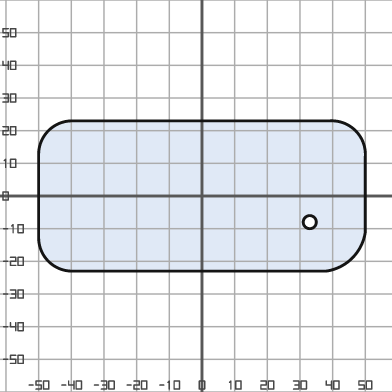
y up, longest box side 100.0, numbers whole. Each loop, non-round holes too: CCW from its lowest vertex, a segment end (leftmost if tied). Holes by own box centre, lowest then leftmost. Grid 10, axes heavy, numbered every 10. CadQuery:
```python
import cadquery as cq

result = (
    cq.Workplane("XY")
    .moveTo(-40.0, -23.0)
    .lineTo(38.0, -23.0)
    .threePointArc((46.0, -19.0), (50.0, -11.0))
    .lineTo(50.0, 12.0)
    .threePointArc((47.0, 20.0), (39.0, 23.0))
    .lineTo(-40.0, 23.0)
    .threePointArc((-47.0, 20.0), (-50.0, 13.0))
    .lineTo(-50.0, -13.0)
    .threePointArc((-47.0, -20.0), (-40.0, -23.0))
    .close()
    .moveTo(33.0, -8.0)
    .circle(2.0)
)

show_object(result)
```